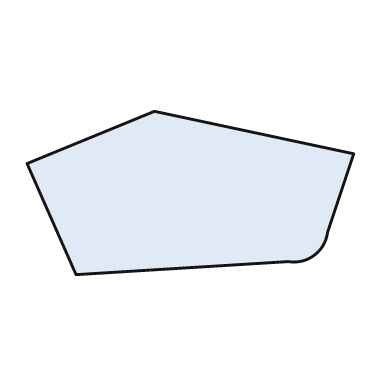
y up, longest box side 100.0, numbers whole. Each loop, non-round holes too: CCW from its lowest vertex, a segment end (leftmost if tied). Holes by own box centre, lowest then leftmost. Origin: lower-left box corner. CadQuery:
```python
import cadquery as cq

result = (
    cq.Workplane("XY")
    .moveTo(15.0, 0.0)
    .lineTo(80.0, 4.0)
    .threePointArc((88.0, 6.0), (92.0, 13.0))
    .lineTo(100.0, 37.0)
    .lineTo(39.0, 50.0)
    .lineTo(0.0, 34.0)
    .close()
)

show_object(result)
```